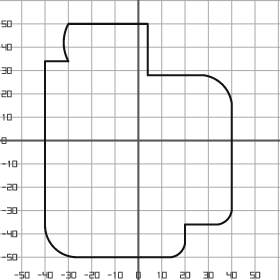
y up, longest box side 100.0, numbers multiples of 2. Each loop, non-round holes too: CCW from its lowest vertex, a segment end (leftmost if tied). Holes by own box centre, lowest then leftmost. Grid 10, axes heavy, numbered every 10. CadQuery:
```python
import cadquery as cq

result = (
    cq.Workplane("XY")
    .moveTo(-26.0, -50.0)
    .lineTo(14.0, -50.0)
    .threePointArc((18.0, -48.0), (20.0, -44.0))
    .lineTo(20.0, -36.0)
    .lineTo(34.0, -36.0)
    .threePointArc((38.0, -34.0), (40.0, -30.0))
    .lineTo(40.0, 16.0)
    .threePointArc((36.0, 24.0), (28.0, 28.0))
    .lineTo(4.0, 28.0)
    .lineTo(4.0, 50.0)
    .lineTo(-30.0, 50.0)
    .threePointArc((-32.0, 42.0), (-30.0, 34.0))
    .lineTo(-40.0, 34.0)
    .lineTo(-40.0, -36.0)
    .threePointArc((-36.0, -46.0), (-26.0, -50.0))
    .close()
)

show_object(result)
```